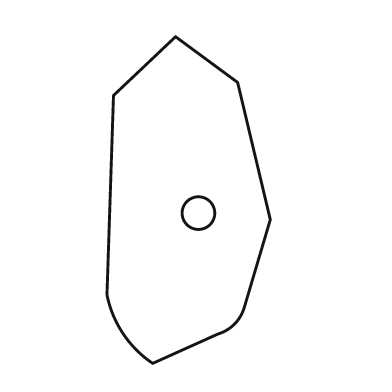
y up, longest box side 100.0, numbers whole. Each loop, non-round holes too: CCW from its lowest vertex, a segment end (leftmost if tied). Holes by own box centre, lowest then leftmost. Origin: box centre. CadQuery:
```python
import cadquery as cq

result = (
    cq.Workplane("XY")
    .moveTo(-11.0, -50.0)
    .lineTo(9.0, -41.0)
    .threePointArc((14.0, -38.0), (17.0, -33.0))
    .lineTo(25.0, -6.0)
    .lineTo(15.0, 36.0)
    .lineTo(-4.0, 50.0)
    .lineTo(-23.0, 32.0)
    .lineTo(-25.0, -29.0)
    .threePointArc((-20.0, -41.0), (-11.0, -50.0))
    .close()
    .moveTo(3.0, -4.0)
    .circle(5.0)
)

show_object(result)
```